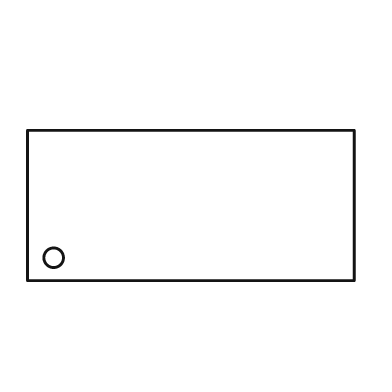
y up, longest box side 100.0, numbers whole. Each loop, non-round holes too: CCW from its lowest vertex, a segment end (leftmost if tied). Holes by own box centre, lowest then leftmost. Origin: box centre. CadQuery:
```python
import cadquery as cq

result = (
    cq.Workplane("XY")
    .moveTo(-50.0, -23.0)
    .lineTo(50.0, -23.0)
    .lineTo(50.0, 23.0)
    .lineTo(-50.0, 23.0)
    .close()
    .moveTo(-42.0, -16.0)
    .circle(3.0)
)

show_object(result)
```